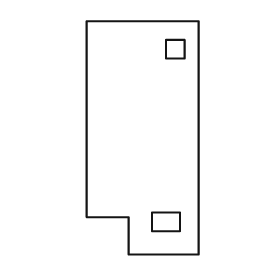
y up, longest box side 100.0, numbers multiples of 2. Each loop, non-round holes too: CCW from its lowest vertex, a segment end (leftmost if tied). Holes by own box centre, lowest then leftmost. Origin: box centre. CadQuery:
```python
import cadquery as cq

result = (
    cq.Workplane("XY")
    .moveTo(-6.0, -50.0)
    .lineTo(24.0, -50.0)
    .lineTo(24.0, 50.0)
    .lineTo(-24.0, 50.0)
    .lineTo(-24.0, -34.0)
    .lineTo(-6.0, -34.0)
    .close()
    .moveTo(4.0, -40.0)
    .lineTo(16.0, -40.0)
    .lineTo(16.0, -32.0)
    .lineTo(4.0, -32.0)
    .close()
    .moveTo(10.0, 34.0)
    .lineTo(18.0, 34.0)
    .lineTo(18.0, 42.0)
    .lineTo(10.0, 42.0)
    .close()
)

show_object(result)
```